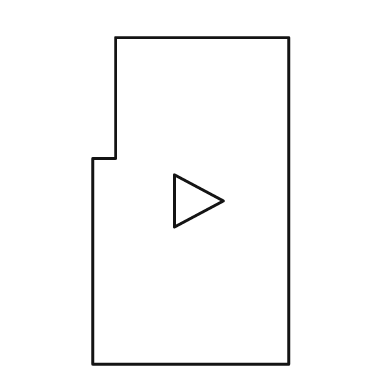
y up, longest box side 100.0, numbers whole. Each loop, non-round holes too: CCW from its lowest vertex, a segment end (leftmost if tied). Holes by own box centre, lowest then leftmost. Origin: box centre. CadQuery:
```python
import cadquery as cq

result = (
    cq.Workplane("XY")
    .moveTo(-30.0, -50.0)
    .lineTo(30.0, -50.0)
    .lineTo(30.0, 50.0)
    .lineTo(-23.0, 50.0)
    .lineTo(-23.0, 13.0)
    .lineTo(-30.0, 13.0)
    .close()
    .moveTo(-5.0, -8.0)
    .lineTo(10.0, 0.0)
    .lineTo(-5.0, 8.0)
    .close()
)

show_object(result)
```